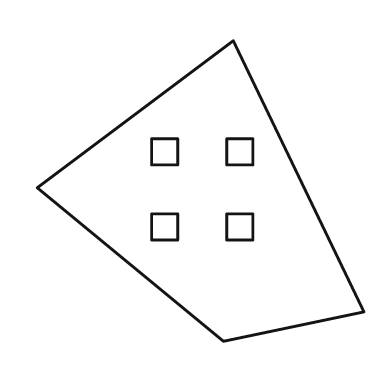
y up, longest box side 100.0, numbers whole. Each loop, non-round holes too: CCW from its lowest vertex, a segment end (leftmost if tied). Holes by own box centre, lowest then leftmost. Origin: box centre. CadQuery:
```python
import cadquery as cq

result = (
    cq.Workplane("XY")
    .moveTo(7.0, -46.0)
    .lineTo(50.0, -37.0)
    .lineTo(10.0, 46.0)
    .lineTo(-50.0, 1.0)
    .close()
    .moveTo(-15.0, -15.0)
    .lineTo(-7.0, -15.0)
    .lineTo(-7.0, -7.0)
    .lineTo(-15.0, -7.0)
    .close()
    .moveTo(8.0, -15.0)
    .lineTo(16.0, -15.0)
    .lineTo(16.0, -7.0)
    .lineTo(8.0, -7.0)
    .close()
    .moveTo(-15.0, 8.0)
    .lineTo(-7.0, 8.0)
    .lineTo(-7.0, 16.0)
    .lineTo(-15.0, 16.0)
    .close()
    .moveTo(8.0, 8.0)
    .lineTo(16.0, 8.0)
    .lineTo(16.0, 16.0)
    .lineTo(8.0, 16.0)
    .close()
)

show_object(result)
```